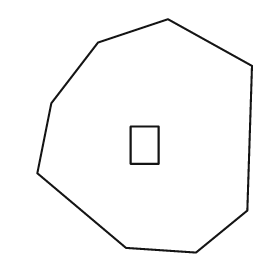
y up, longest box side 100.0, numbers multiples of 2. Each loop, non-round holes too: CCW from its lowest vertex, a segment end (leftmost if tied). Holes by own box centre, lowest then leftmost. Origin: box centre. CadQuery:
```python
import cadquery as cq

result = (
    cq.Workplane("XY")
    .moveTo(22.0, -50.0)
    .lineTo(44.0, -32.0)
    .lineTo(46.0, 30.0)
    .lineTo(10.0, 50.0)
    .lineTo(-20.0, 40.0)
    .lineTo(-40.0, 14.0)
    .lineTo(-46.0, -16.0)
    .lineTo(-8.0, -48.0)
    .close()
    .moveTo(-6.0, -12.0)
    .lineTo(6.0, -12.0)
    .lineTo(6.0, 4.0)
    .lineTo(-6.0, 4.0)
    .close()
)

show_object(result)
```